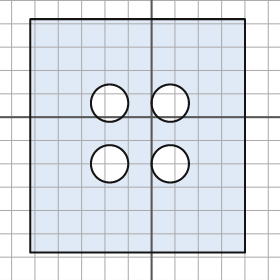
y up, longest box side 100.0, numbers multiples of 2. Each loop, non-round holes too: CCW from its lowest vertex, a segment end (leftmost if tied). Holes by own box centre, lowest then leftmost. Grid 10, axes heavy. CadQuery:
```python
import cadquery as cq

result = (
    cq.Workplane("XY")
    .moveTo(-52.0, -58.0)
    .lineTo(40.0, -58.0)
    .lineTo(40.0, 42.0)
    .lineTo(-52.0, 42.0)
    .close()
    .moveTo(-18.0, -20.0)
    .circle(8.0)
    .moveTo(8.0, -20.0)
    .circle(8.0)
    .moveTo(-18.0, 6.0)
    .circle(8.0)
    .moveTo(8.0, 6.0)
    .circle(8.0)
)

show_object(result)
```